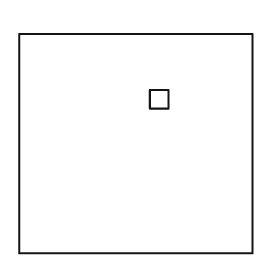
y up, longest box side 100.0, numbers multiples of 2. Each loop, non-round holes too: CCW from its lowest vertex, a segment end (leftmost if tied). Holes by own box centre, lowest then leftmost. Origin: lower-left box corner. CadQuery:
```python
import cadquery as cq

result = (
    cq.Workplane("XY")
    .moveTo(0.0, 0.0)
    .lineTo(100.0, 0.0)
    .lineTo(100.0, 94.0)
    .lineTo(0.0, 94.0)
    .close()
    .moveTo(56.0, 62.0)
    .lineTo(64.0, 62.0)
    .lineTo(64.0, 70.0)
    .lineTo(56.0, 70.0)
    .close()
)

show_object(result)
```